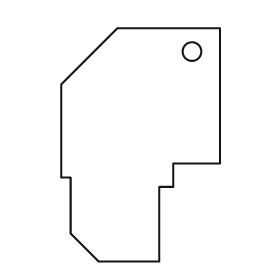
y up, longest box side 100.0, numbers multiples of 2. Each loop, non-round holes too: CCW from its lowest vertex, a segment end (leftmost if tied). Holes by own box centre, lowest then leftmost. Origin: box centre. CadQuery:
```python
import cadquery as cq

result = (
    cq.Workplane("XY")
    .moveTo(-18.0, -50.0)
    .lineTo(8.0, -50.0)
    .lineTo(8.0, -18.0)
    .lineTo(14.0, -18.0)
    .lineTo(14.0, -8.0)
    .lineTo(34.0, -8.0)
    .lineTo(34.0, 50.0)
    .lineTo(-10.0, 50.0)
    .lineTo(-34.0, 26.0)
    .lineTo(-34.0, -14.0)
    .lineTo(-30.0, -14.0)
    .lineTo(-30.0, -38.0)
    .close()
    .moveTo(22.0, 40.0)
    .circle(4.0)
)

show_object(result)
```